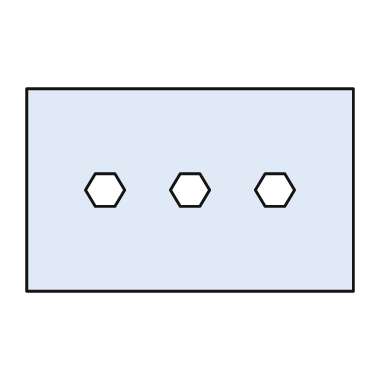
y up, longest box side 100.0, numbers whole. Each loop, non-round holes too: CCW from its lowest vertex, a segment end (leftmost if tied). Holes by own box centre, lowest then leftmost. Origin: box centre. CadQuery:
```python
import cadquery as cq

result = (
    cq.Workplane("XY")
    .moveTo(-50.0, -31.0)
    .lineTo(50.0, -31.0)
    .lineTo(50.0, 31.0)
    .lineTo(-50.0, 31.0)
    .close()
    .moveTo(-29.0, -5.0)
    .lineTo(-23.0, -5.0)
    .lineTo(-20.0, 0.0)
    .lineTo(-23.0, 5.0)
    .lineTo(-29.0, 5.0)
    .lineTo(-32.0, 0.0)
    .close()
    .moveTo(-3.0, -5.0)
    .lineTo(3.0, -5.0)
    .lineTo(6.0, 0.0)
    .lineTo(3.0, 5.0)
    .lineTo(-3.0, 5.0)
    .lineTo(-6.0, 0.0)
    .close()
    .moveTo(23.0, -5.0)
    .lineTo(29.0, -5.0)
    .lineTo(32.0, 0.0)
    .lineTo(29.0, 5.0)
    .lineTo(23.0, 5.0)
    .lineTo(20.0, 0.0)
    .close()
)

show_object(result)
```